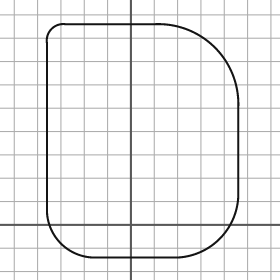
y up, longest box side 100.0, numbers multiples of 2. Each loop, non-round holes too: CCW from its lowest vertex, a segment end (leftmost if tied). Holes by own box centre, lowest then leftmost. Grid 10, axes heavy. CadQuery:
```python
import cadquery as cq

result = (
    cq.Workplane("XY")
    .moveTo(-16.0, -14.0)
    .lineTo(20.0, -14.0)
    .threePointArc((38.0, -6.0), (46.0, 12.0))
    .lineTo(46.0, 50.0)
    .threePointArc((36.0, 76.0), (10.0, 86.0))
    .lineTo(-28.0, 86.0)
    .threePointArc((-34.0, 84.0), (-36.0, 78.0))
    .lineTo(-36.0, 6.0)
    .threePointArc((-30.0, -8.0), (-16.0, -14.0))
    .close()
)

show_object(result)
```